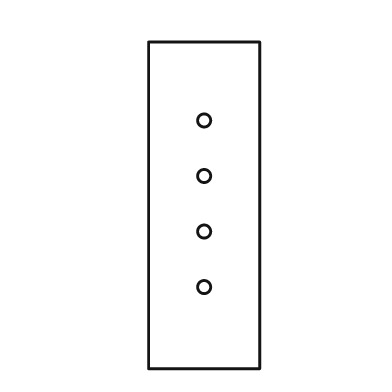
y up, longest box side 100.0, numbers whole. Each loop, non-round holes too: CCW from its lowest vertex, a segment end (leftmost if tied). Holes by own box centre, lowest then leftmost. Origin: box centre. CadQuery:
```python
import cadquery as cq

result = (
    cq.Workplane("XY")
    .moveTo(-17.0, -50.0)
    .lineTo(17.0, -50.0)
    .lineTo(17.0, 50.0)
    .lineTo(-17.0, 50.0)
    .close()
    .moveTo(0.0, -25.0)
    .circle(2.0)
    .moveTo(0.0, -8.0)
    .circle(2.0)
    .moveTo(0.0, 9.0)
    .circle(2.0)
    .moveTo(0.0, 26.0)
    .circle(2.0)
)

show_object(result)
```